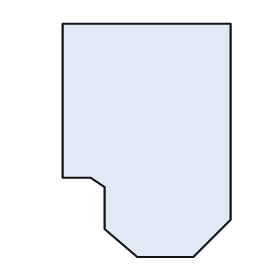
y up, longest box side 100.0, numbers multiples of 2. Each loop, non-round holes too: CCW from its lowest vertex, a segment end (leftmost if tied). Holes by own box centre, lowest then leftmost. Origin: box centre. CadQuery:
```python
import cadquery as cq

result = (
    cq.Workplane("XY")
    .moveTo(-4.0, -50.0)
    .lineTo(20.0, -50.0)
    .lineTo(36.0, -34.0)
    .lineTo(36.0, 50.0)
    .lineTo(-36.0, 50.0)
    .lineTo(-36.0, -16.0)
    .lineTo(-24.0, -16.0)
    .lineTo(-18.0, -20.0)
    .lineTo(-18.0, -38.0)
    .close()
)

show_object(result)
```